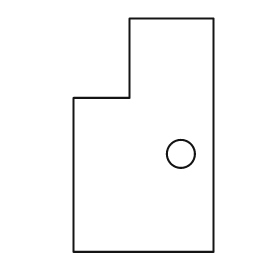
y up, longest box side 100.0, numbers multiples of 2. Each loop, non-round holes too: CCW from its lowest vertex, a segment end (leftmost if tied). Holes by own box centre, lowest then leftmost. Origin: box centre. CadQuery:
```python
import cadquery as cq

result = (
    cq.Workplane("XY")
    .moveTo(-30.0, -50.0)
    .lineTo(30.0, -50.0)
    .lineTo(30.0, 50.0)
    .lineTo(-6.0, 50.0)
    .lineTo(-6.0, 16.0)
    .lineTo(-30.0, 16.0)
    .close()
    .moveTo(16.0, -8.0)
    .circle(6.0)
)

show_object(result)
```